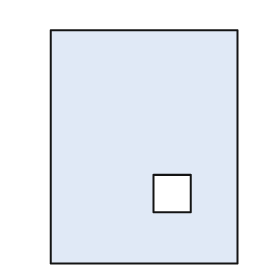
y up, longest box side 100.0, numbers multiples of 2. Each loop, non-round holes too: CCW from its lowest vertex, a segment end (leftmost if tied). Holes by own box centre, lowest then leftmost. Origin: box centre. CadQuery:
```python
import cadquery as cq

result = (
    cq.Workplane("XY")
    .moveTo(-40.0, -50.0)
    .lineTo(40.0, -50.0)
    .lineTo(40.0, 50.0)
    .lineTo(-40.0, 50.0)
    .close()
    .moveTo(4.0, -28.0)
    .lineTo(20.0, -28.0)
    .lineTo(20.0, -12.0)
    .lineTo(4.0, -12.0)
    .close()
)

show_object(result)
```